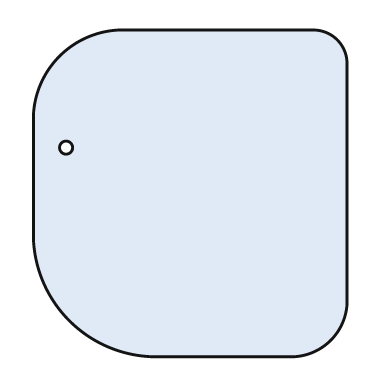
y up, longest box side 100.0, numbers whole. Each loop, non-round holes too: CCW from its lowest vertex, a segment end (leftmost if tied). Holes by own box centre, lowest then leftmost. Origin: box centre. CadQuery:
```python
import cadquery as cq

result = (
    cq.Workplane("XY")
    .moveTo(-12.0, -50.0)
    .lineTo(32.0, -50.0)
    .threePointArc((43.0, -45.0), (48.0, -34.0))
    .lineTo(48.0, 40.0)
    .threePointArc((45.0, 47.0), (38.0, 50.0))
    .lineTo(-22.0, 50.0)
    .threePointArc((-40.0, 42.0), (-48.0, 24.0))
    .lineTo(-48.0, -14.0)
    .threePointArc((-37.0, -39.0), (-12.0, -50.0))
    .close()
    .moveTo(-38.0, 14.0)
    .circle(2.0)
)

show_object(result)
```